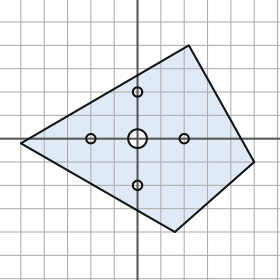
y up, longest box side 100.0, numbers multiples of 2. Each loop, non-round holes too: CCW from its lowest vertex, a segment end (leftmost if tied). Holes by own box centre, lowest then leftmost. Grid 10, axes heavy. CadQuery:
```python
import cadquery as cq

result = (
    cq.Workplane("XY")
    .moveTo(16.0, -40.0)
    .lineTo(50.0, -10.0)
    .lineTo(22.0, 40.0)
    .lineTo(-50.0, -2.0)
    .close()
    .moveTo(0.0, -20.0)
    .circle(2.0)
    .moveTo(-20.0, 0.0)
    .circle(2.0)
    .moveTo(0.0, 0.0)
    .circle(4.0)
    .moveTo(20.0, 0.0)
    .circle(2.0)
    .moveTo(0.0, 20.0)
    .circle(2.0)
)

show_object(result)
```